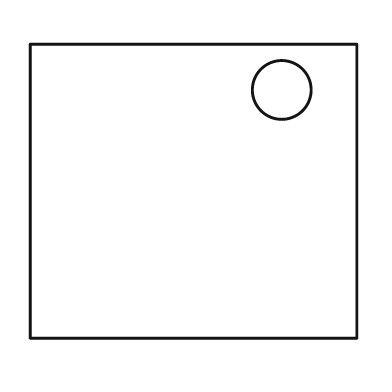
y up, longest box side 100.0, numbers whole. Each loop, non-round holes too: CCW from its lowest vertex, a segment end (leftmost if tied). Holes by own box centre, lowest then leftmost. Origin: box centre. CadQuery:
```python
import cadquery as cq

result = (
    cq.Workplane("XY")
    .moveTo(-50.0, -45.0)
    .lineTo(50.0, -45.0)
    .lineTo(50.0, 45.0)
    .lineTo(-50.0, 45.0)
    .close()
    .moveTo(27.0, 31.0)
    .circle(9.0)
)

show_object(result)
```